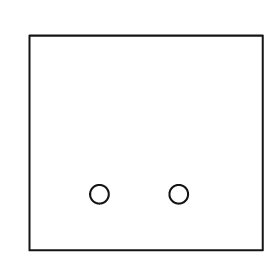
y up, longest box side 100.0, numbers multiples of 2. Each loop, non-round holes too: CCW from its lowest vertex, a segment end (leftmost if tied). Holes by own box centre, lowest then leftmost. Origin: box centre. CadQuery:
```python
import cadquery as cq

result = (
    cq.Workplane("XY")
    .moveTo(-50.0, -46.0)
    .lineTo(50.0, -46.0)
    .lineTo(50.0, 46.0)
    .lineTo(-50.0, 46.0)
    .close()
    .moveTo(-20.0, -22.0)
    .circle(4.0)
    .moveTo(14.0, -22.0)
    .circle(4.0)
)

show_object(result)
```